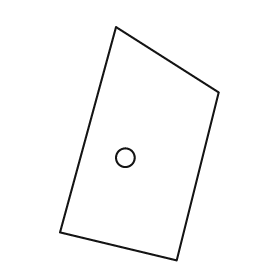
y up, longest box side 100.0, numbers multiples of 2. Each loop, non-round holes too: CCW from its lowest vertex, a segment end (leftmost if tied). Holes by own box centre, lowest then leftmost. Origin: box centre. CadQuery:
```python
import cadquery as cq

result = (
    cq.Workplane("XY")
    .moveTo(16.0, -50.0)
    .lineTo(34.0, 22.0)
    .lineTo(-10.0, 50.0)
    .lineTo(-34.0, -38.0)
    .close()
    .moveTo(-6.0, -6.0)
    .circle(4.0)
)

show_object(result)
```